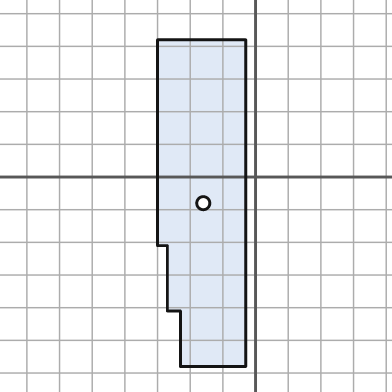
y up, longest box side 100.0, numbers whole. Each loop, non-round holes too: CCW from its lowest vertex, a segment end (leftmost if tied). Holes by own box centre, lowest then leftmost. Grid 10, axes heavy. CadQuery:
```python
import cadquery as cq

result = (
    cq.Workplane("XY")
    .moveTo(-23.0, -58.0)
    .lineTo(-3.0, -58.0)
    .lineTo(-3.0, 42.0)
    .lineTo(-30.0, 42.0)
    .lineTo(-30.0, -21.0)
    .lineTo(-27.0, -21.0)
    .lineTo(-27.0, -41.0)
    .lineTo(-23.0, -41.0)
    .close()
    .moveTo(-16.0, -8.0)
    .circle(2.0)
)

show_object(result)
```